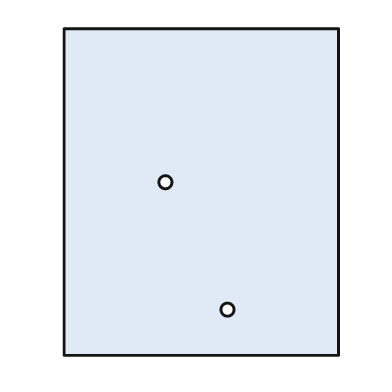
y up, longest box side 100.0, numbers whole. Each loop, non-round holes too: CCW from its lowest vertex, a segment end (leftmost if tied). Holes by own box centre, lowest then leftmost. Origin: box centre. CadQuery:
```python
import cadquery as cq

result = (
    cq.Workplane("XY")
    .moveTo(-42.0, -50.0)
    .lineTo(42.0, -50.0)
    .lineTo(42.0, 50.0)
    .lineTo(-42.0, 50.0)
    .close()
    .moveTo(8.0, -36.0)
    .circle(2.0)
    .moveTo(-11.0, 3.0)
    .circle(2.0)
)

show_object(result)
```